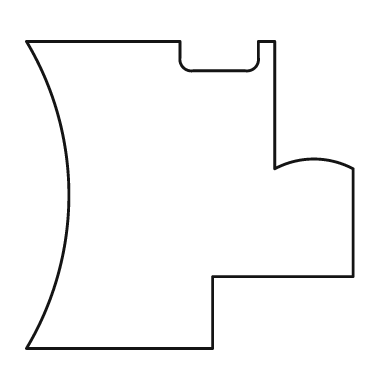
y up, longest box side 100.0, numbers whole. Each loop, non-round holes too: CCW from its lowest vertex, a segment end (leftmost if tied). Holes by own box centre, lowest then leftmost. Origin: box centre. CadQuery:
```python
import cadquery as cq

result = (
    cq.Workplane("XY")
    .moveTo(-50.0, -47.0)
    .lineTo(7.0, -47.0)
    .lineTo(7.0, -25.0)
    .lineTo(50.0, -25.0)
    .lineTo(50.0, 8.0)
    .threePointArc((38.0, 11.0), (26.0, 8.0))
    .lineTo(26.0, 47.0)
    .lineTo(21.0, 47.0)
    .lineTo(21.0, 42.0)
    .threePointArc((20.0, 39.0), (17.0, 38.0))
    .lineTo(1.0, 38.0)
    .threePointArc((-2.0, 39.0), (-3.0, 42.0))
    .lineTo(-3.0, 47.0)
    .lineTo(-50.0, 47.0)
    .threePointArc((-37.0, 0.0), (-50.0, -47.0))
    .close()
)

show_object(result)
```